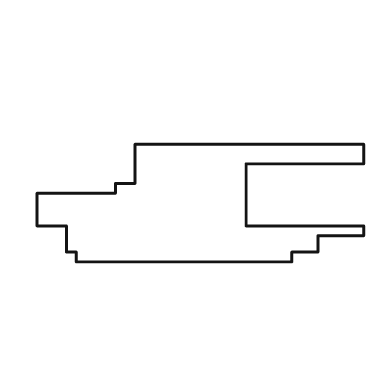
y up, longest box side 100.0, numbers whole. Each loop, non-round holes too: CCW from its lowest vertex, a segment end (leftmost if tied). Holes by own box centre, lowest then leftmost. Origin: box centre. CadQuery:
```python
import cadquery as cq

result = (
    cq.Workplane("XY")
    .moveTo(-38.0, -18.0)
    .lineTo(28.0, -18.0)
    .lineTo(28.0, -15.0)
    .lineTo(36.0, -15.0)
    .lineTo(36.0, -10.0)
    .lineTo(50.0, -10.0)
    .lineTo(50.0, -7.0)
    .lineTo(14.0, -7.0)
    .lineTo(14.0, 12.0)
    .lineTo(50.0, 12.0)
    .lineTo(50.0, 18.0)
    .lineTo(-20.0, 18.0)
    .lineTo(-20.0, 6.0)
    .lineTo(-26.0, 6.0)
    .lineTo(-26.0, 3.0)
    .lineTo(-50.0, 3.0)
    .lineTo(-50.0, -7.0)
    .lineTo(-41.0, -7.0)
    .lineTo(-41.0, -15.0)
    .lineTo(-38.0, -15.0)
    .close()
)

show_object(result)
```